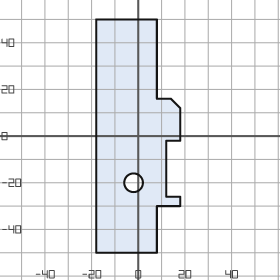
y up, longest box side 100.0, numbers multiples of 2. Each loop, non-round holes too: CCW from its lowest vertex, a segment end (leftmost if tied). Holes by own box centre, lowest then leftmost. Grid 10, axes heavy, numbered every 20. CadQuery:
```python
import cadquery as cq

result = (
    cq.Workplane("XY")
    .moveTo(-18.0, -50.0)
    .lineTo(8.0, -50.0)
    .lineTo(8.0, -30.0)
    .lineTo(18.0, -30.0)
    .lineTo(18.0, -26.0)
    .lineTo(12.0, -26.0)
    .lineTo(12.0, -2.0)
    .lineTo(18.0, -2.0)
    .lineTo(18.0, 12.0)
    .lineTo(14.0, 16.0)
    .lineTo(8.0, 16.0)
    .lineTo(8.0, 50.0)
    .lineTo(-18.0, 50.0)
    .close()
    .moveTo(-2.0, -20.0)
    .circle(4.0)
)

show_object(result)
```